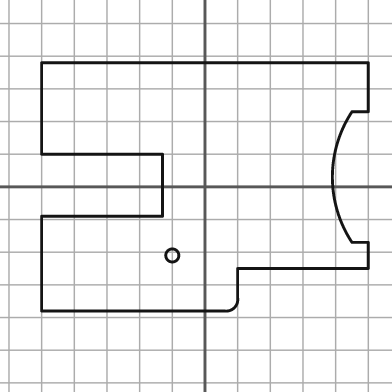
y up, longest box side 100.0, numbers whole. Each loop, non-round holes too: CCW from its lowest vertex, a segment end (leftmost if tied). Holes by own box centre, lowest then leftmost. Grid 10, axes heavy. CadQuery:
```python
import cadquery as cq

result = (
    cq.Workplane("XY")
    .moveTo(-50.0, -38.0)
    .lineTo(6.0, -38.0)
    .threePointArc((9.0, -37.0), (10.0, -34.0))
    .lineTo(10.0, -25.0)
    .lineTo(50.0, -25.0)
    .lineTo(50.0, -17.0)
    .lineTo(45.0, -17.0)
    .threePointArc((39.0, 3.0), (45.0, 23.0))
    .lineTo(50.0, 23.0)
    .lineTo(50.0, 38.0)
    .lineTo(-50.0, 38.0)
    .lineTo(-50.0, 10.0)
    .lineTo(-13.0, 10.0)
    .lineTo(-13.0, -9.0)
    .lineTo(-50.0, -9.0)
    .close()
    .moveTo(-10.0, -21.0)
    .circle(2.0)
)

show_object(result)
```